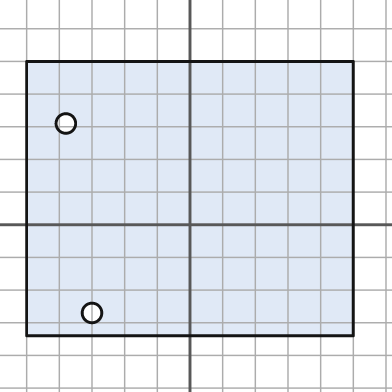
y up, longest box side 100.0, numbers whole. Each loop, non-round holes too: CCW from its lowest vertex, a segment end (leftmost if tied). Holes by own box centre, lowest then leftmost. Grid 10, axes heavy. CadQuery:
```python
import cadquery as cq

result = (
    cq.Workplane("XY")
    .moveTo(-50.0, -34.0)
    .lineTo(50.0, -34.0)
    .lineTo(50.0, 50.0)
    .lineTo(-50.0, 50.0)
    .close()
    .moveTo(-30.0, -27.0)
    .circle(3.0)
    .moveTo(-38.0, 31.0)
    .circle(3.0)
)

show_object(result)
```